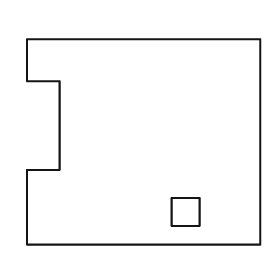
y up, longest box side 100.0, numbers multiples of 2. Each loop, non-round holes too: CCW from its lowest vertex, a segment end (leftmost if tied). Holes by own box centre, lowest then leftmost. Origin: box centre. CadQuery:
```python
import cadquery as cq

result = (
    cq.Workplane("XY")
    .moveTo(-50.0, -44.0)
    .lineTo(50.0, -44.0)
    .lineTo(50.0, 44.0)
    .lineTo(-50.0, 44.0)
    .lineTo(-50.0, 26.0)
    .lineTo(-36.0, 26.0)
    .lineTo(-36.0, -12.0)
    .lineTo(-50.0, -12.0)
    .close()
    .moveTo(12.0, -36.0)
    .lineTo(24.0, -36.0)
    .lineTo(24.0, -24.0)
    .lineTo(12.0, -24.0)
    .close()
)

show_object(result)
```